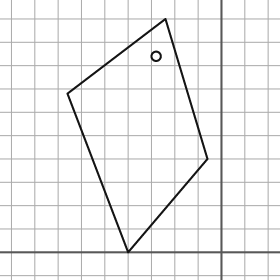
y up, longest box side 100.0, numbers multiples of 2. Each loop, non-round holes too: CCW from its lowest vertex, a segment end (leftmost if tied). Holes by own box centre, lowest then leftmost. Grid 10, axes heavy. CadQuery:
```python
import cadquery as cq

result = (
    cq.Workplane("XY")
    .moveTo(-40.0, 0.0)
    .lineTo(-6.0, 40.0)
    .lineTo(-24.0, 100.0)
    .lineTo(-66.0, 68.0)
    .close()
    .moveTo(-28.0, 84.0)
    .circle(2.0)
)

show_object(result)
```